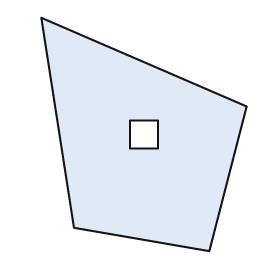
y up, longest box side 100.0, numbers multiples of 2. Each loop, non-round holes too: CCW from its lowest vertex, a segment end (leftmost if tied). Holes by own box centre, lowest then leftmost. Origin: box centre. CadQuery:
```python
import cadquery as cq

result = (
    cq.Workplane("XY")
    .moveTo(28.0, -50.0)
    .lineTo(44.0, 12.0)
    .lineTo(-44.0, 50.0)
    .lineTo(-30.0, -40.0)
    .close()
    .moveTo(-6.0, -6.0)
    .lineTo(6.0, -6.0)
    .lineTo(6.0, 6.0)
    .lineTo(-6.0, 6.0)
    .close()
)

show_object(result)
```